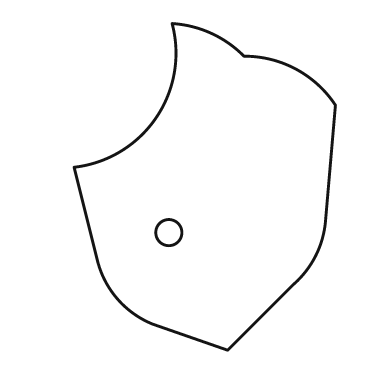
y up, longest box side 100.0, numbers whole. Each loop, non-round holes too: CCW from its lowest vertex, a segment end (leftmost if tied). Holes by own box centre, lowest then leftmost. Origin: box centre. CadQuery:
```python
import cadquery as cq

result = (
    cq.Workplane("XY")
    .moveTo(7.0, -50.0)
    .lineTo(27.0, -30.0)
    .threePointArc((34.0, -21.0), (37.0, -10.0))
    .lineTo(40.0, 25.0)
    .threePointArc((28.0, 36.0), (12.0, 40.0))
    .threePointArc((2.0, 47.0), (-10.0, 50.0))
    .threePointArc((-15.0, 21.0), (-40.0, 6.0))
    .lineTo(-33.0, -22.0)
    .threePointArc((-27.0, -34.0), (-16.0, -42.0))
    .close()
    .moveTo(-11.0, -14.0)
    .circle(4.0)
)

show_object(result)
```